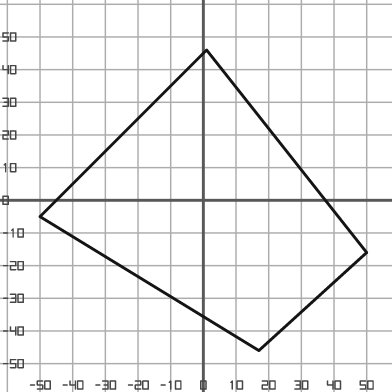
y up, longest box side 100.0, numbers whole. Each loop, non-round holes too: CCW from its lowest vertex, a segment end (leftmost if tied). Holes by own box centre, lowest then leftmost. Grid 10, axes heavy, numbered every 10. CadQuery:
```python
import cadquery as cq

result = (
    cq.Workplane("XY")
    .moveTo(17.0, -46.0)
    .lineTo(50.0, -16.0)
    .lineTo(1.0, 46.0)
    .lineTo(-50.0, -5.0)
    .close()
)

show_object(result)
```